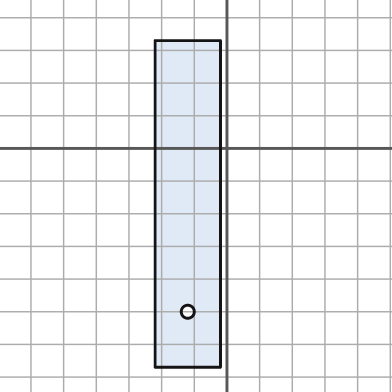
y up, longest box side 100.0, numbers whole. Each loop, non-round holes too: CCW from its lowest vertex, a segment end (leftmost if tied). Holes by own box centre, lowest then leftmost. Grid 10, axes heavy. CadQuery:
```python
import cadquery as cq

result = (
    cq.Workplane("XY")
    .moveTo(-22.0, -67.0)
    .lineTo(-2.0, -67.0)
    .lineTo(-2.0, 33.0)
    .lineTo(-22.0, 33.0)
    .close()
    .moveTo(-12.0, -50.0)
    .circle(2.0)
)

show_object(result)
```